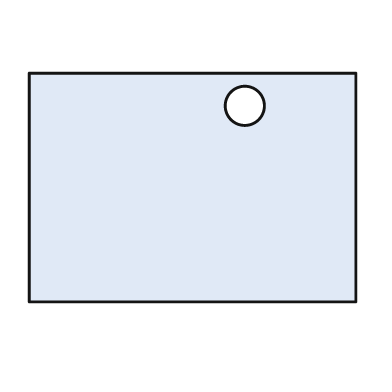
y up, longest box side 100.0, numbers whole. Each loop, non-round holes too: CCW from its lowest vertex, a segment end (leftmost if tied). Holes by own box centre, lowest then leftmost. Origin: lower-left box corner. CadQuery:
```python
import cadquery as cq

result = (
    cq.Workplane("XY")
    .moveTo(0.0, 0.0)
    .lineTo(100.0, 0.0)
    .lineTo(100.0, 70.0)
    .lineTo(0.0, 70.0)
    .close()
    .moveTo(66.0, 60.0)
    .circle(6.0)
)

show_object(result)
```